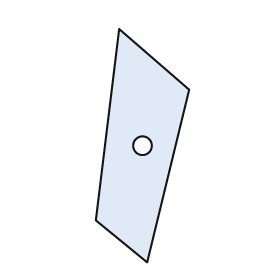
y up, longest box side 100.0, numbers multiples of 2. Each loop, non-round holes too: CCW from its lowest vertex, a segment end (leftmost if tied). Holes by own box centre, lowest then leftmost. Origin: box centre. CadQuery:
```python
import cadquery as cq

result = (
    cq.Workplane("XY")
    .moveTo(2.0, -50.0)
    .lineTo(20.0, 24.0)
    .lineTo(-10.0, 50.0)
    .lineTo(-20.0, -32.0)
    .close()
    .moveTo(0.0, 0.0)
    .circle(4.0)
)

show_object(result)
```